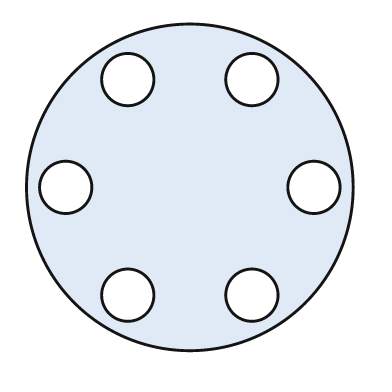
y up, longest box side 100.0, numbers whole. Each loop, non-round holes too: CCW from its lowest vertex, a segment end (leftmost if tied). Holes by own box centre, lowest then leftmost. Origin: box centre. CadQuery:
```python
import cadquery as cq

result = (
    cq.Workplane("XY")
    .moveTo(0.0, 0.0)
    .circle(50.0)
    .moveTo(-19.0, -33.0)
    .circle(8.0)
    .moveTo(19.0, -33.0)
    .circle(8.0)
    .moveTo(-38.0, 0.0)
    .circle(8.0)
    .moveTo(38.0, 0.0)
    .circle(8.0)
    .moveTo(-19.0, 33.0)
    .circle(8.0)
    .moveTo(19.0, 33.0)
    .circle(8.0)
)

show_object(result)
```